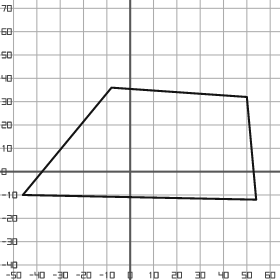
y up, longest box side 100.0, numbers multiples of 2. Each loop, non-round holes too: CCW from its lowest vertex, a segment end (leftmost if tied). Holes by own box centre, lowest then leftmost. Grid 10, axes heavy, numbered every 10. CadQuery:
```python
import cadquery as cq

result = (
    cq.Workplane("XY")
    .moveTo(54.0, -12.0)
    .lineTo(50.0, 32.0)
    .lineTo(-8.0, 36.0)
    .lineTo(-46.0, -10.0)
    .close()
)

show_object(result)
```